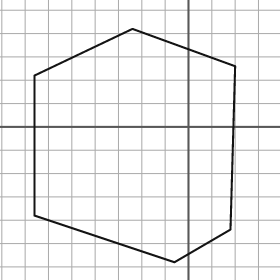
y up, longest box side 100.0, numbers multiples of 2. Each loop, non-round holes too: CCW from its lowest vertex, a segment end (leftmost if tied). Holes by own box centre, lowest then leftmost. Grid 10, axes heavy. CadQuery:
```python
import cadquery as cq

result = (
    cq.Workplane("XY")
    .moveTo(-6.0, -58.0)
    .lineTo(18.0, -44.0)
    .lineTo(20.0, 26.0)
    .lineTo(-24.0, 42.0)
    .lineTo(-66.0, 22.0)
    .lineTo(-66.0, -38.0)
    .close()
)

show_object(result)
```